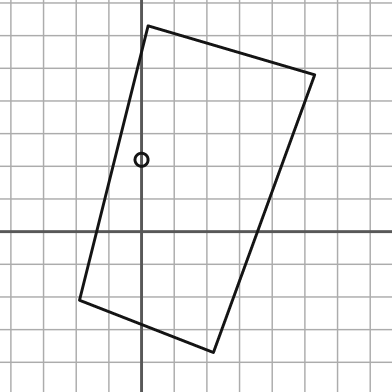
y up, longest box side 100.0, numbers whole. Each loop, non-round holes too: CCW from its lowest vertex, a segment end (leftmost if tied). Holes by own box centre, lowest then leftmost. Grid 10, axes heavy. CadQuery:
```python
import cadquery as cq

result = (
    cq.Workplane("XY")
    .moveTo(22.0, -37.0)
    .lineTo(53.0, 48.0)
    .lineTo(2.0, 63.0)
    .lineTo(-19.0, -21.0)
    .close()
    .moveTo(0.0, 22.0)
    .circle(2.0)
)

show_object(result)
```